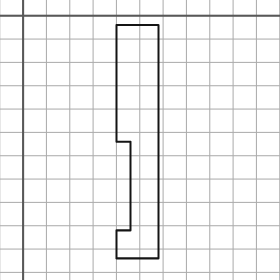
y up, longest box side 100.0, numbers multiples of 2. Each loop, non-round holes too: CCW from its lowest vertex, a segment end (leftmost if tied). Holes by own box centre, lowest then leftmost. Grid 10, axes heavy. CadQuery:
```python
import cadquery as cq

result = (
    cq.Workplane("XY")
    .moveTo(40.0, -104.0)
    .lineTo(58.0, -104.0)
    .lineTo(58.0, -4.0)
    .lineTo(40.0, -4.0)
    .lineTo(40.0, -54.0)
    .lineTo(46.0, -54.0)
    .lineTo(46.0, -92.0)
    .lineTo(40.0, -92.0)
    .close()
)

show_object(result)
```